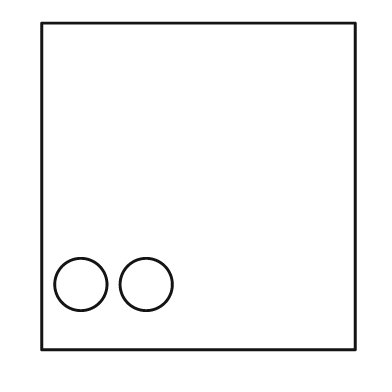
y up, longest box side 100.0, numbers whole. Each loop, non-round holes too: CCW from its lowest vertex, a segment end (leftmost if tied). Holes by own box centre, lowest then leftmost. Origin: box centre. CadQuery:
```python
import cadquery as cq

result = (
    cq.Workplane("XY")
    .moveTo(-48.0, -50.0)
    .lineTo(48.0, -50.0)
    .lineTo(48.0, 50.0)
    .lineTo(-48.0, 50.0)
    .close()
    .moveTo(-36.0, -30.0)
    .circle(8.0)
    .moveTo(-16.0, -30.0)
    .circle(8.0)
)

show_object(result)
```